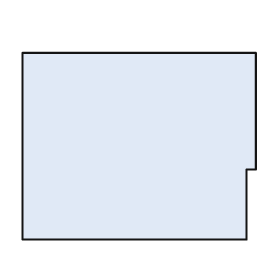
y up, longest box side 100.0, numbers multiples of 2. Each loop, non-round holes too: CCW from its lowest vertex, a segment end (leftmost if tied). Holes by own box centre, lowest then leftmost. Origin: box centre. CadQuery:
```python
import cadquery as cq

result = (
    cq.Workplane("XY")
    .moveTo(-50.0, -40.0)
    .lineTo(46.0, -40.0)
    .lineTo(46.0, -10.0)
    .lineTo(50.0, -10.0)
    .lineTo(50.0, 40.0)
    .lineTo(-50.0, 40.0)
    .close()
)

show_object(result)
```